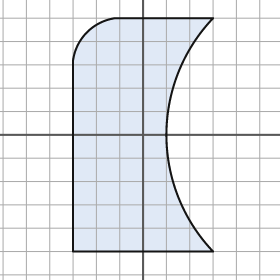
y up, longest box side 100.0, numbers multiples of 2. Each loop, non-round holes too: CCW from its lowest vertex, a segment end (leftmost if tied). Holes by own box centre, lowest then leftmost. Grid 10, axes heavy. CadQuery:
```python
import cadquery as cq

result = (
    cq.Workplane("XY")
    .moveTo(-30.0, -50.0)
    .lineTo(30.0, -50.0)
    .threePointArc((10.0, 0.0), (30.0, 50.0))
    .lineTo(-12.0, 50.0)
    .threePointArc((-24.0, 44.0), (-30.0, 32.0))
    .close()
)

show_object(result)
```